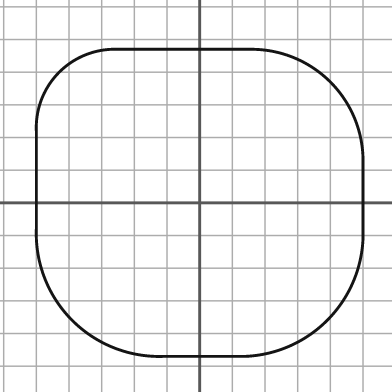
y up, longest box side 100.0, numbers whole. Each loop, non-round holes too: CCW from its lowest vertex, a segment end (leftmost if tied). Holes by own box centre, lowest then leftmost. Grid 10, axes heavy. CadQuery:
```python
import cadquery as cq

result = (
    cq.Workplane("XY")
    .moveTo(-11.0, -47.0)
    .lineTo(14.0, -47.0)
    .threePointArc((39.0, -36.0), (50.0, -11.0))
    .lineTo(50.0, 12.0)
    .threePointArc((40.0, 37.0), (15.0, 47.0))
    .lineTo(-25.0, 47.0)
    .threePointArc((-43.0, 40.0), (-50.0, 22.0))
    .lineTo(-50.0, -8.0)
    .threePointArc((-39.0, -36.0), (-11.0, -47.0))
    .close()
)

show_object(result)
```